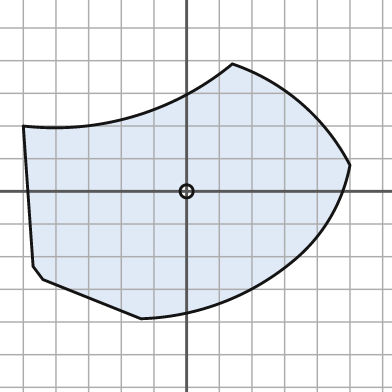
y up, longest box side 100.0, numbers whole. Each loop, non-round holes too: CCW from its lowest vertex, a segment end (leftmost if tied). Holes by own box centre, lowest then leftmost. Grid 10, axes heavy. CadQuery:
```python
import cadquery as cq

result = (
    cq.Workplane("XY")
    .moveTo(-14.0, -39.0)
    .threePointArc((11.0, -34.0), (33.0, -21.0))
    .threePointArc((44.0, -8.0), (50.0, 8.0))
    .threePointArc((35.0, 27.0), (14.0, 39.0))
    .threePointArc((-16.0, 23.0), (-50.0, 20.0))
    .lineTo(-47.0, -23.0)
    .lineTo(-44.0, -27.0)
    .close()
    .moveTo(0.0, 0.0)
    .circle(2.0)
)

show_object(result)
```